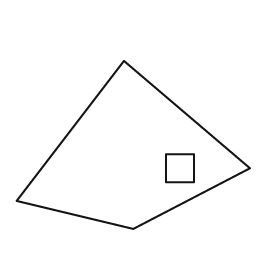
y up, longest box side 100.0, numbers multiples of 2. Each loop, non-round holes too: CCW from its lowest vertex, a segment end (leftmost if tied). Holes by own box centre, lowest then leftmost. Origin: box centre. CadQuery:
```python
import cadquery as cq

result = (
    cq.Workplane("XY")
    .moveTo(0.0, -36.0)
    .lineTo(50.0, -10.0)
    .lineTo(-4.0, 36.0)
    .lineTo(-50.0, -24.0)
    .close()
    .moveTo(14.0, -16.0)
    .lineTo(26.0, -16.0)
    .lineTo(26.0, -4.0)
    .lineTo(14.0, -4.0)
    .close()
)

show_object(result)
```